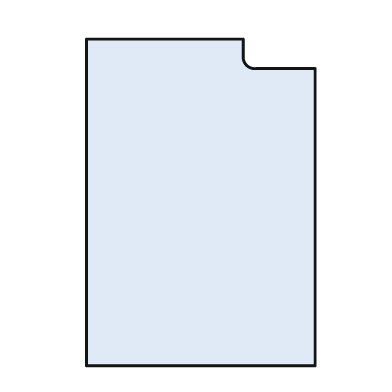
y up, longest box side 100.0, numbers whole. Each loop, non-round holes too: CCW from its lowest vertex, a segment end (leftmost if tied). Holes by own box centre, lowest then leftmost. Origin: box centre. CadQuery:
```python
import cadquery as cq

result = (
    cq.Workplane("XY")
    .moveTo(-35.0, -50.0)
    .lineTo(35.0, -50.0)
    .lineTo(35.0, 41.0)
    .lineTo(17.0, 41.0)
    .threePointArc((14.0, 42.0), (13.0, 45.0))
    .lineTo(13.0, 50.0)
    .lineTo(-35.0, 50.0)
    .close()
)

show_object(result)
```